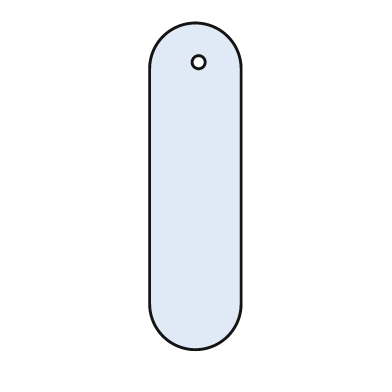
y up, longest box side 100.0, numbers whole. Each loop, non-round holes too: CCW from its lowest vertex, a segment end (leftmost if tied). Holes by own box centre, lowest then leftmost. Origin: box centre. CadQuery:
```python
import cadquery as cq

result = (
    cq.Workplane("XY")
    .moveTo(-14.0, -36.0)
    .threePointArc((0.0, -50.0), (14.0, -36.0))
    .lineTo(14.0, 36.0)
    .threePointArc((0.0, 50.0), (-14.0, 36.0))
    .close()
    .moveTo(1.0, 38.0)
    .circle(2.0)
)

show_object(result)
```